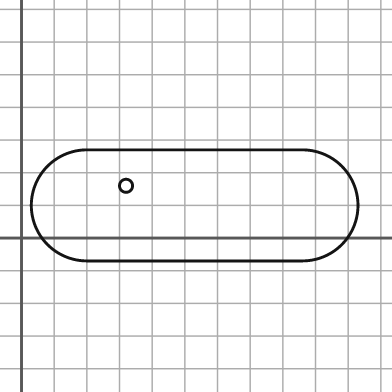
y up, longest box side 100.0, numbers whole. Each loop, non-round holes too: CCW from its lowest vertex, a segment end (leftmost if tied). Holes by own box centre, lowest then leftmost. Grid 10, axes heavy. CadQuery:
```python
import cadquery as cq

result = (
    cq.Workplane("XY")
    .moveTo(20.0, -7.0)
    .lineTo(86.0, -7.0)
    .threePointArc((103.0, 10.0), (86.0, 27.0))
    .lineTo(20.0, 27.0)
    .threePointArc((3.0, 10.0), (20.0, -7.0))
    .close()
    .moveTo(32.0, 16.0)
    .circle(2.0)
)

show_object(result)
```